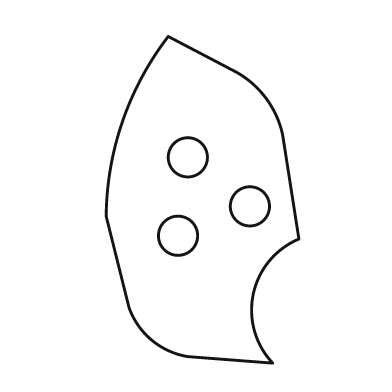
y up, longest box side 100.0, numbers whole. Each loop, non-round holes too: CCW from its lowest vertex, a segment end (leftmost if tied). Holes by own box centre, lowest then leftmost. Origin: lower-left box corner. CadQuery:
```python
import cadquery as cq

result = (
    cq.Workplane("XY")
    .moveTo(51.0, 0.0)
    .threePointArc((45.0, 21.0), (59.0, 38.0))
    .lineTo(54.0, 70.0)
    .threePointArc((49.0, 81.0), (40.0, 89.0))
    .lineTo(19.0, 100.0)
    .threePointArc((5.0, 74.0), (0.0, 45.0))
    .lineTo(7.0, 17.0)
    .threePointArc((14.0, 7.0), (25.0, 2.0))
    .close()
    .moveTo(22.0, 39.0)
    .circle(6.0)
    .moveTo(44.0, 48.0)
    .circle(6.0)
    .moveTo(25.0, 63.0)
    .circle(6.0)
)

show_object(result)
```